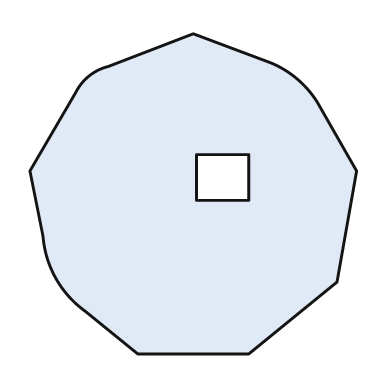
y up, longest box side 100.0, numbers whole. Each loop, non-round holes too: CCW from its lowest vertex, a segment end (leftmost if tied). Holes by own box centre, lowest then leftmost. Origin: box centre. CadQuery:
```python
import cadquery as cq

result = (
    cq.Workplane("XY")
    .moveTo(-17.0, -49.0)
    .lineTo(17.0, -49.0)
    .lineTo(44.0, -27.0)
    .lineTo(50.0, 7.0)
    .lineTo(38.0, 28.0)
    .threePointArc((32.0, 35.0), (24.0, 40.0))
    .lineTo(0.0, 49.0)
    .lineTo(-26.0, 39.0)
    .threePointArc((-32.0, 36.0), (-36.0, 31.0))
    .lineTo(-50.0, 7.0)
    .lineTo(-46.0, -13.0)
    .threePointArc((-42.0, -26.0), (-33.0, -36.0))
    .close()
    .moveTo(1.0, -2.0)
    .lineTo(17.0, -2.0)
    .lineTo(17.0, 12.0)
    .lineTo(1.0, 12.0)
    .close()
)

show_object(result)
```